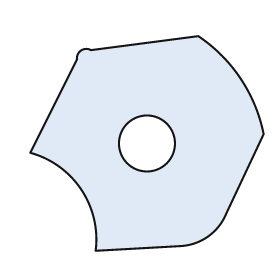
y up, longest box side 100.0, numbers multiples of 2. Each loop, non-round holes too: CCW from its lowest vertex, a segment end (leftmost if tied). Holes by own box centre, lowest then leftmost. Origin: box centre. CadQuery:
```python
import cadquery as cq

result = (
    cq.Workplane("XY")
    .moveTo(-22.0, -46.0)
    .lineTo(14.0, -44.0)
    .threePointArc((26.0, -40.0), (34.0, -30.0))
    .lineTo(50.0, 4.0)
    .threePointArc((40.0, 28.0), (22.0, 46.0))
    .lineTo(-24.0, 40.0)
    .threePointArc((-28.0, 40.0), (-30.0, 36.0))
    .lineTo(-50.0, -4.0)
    .threePointArc((-28.0, -20.0), (-22.0, -46.0))
    .close()
    .moveTo(0.0, 0.0)
    .circle(12.0)
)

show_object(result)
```